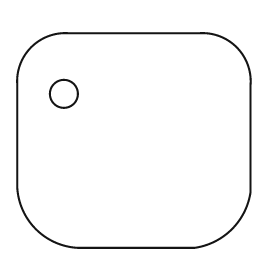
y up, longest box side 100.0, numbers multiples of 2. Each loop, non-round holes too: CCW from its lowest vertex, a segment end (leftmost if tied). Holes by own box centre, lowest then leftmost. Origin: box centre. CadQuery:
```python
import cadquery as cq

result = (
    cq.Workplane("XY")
    .moveTo(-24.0, -46.0)
    .lineTo(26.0, -46.0)
    .threePointArc((42.0, -38.0), (50.0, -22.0))
    .lineTo(50.0, 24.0)
    .threePointArc((44.0, 40.0), (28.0, 46.0))
    .lineTo(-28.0, 46.0)
    .threePointArc((-44.0, 40.0), (-50.0, 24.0))
    .lineTo(-50.0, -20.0)
    .threePointArc((-42.0, -38.0), (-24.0, -46.0))
    .close()
    .moveTo(-30.0, 20.0)
    .circle(6.0)
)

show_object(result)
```